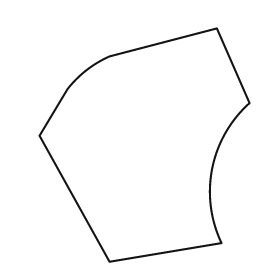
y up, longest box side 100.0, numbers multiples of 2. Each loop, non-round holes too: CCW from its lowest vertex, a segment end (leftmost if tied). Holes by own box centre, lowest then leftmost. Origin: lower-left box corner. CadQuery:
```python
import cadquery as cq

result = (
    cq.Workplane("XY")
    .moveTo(30.0, 0.0)
    .lineTo(78.0, 8.0)
    .threePointArc((74.0, 40.0), (90.0, 68.0))
    .lineTo(76.0, 100.0)
    .lineTo(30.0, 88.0)
    .threePointArc((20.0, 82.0), (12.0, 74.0))
    .lineTo(0.0, 54.0)
    .close()
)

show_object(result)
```